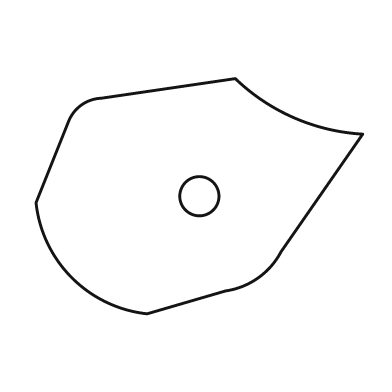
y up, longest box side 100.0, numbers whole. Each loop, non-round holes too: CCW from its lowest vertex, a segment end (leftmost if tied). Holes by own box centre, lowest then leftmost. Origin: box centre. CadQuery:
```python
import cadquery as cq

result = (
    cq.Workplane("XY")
    .moveTo(-16.0, -36.0)
    .lineTo(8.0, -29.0)
    .threePointArc((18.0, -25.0), (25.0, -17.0))
    .lineTo(50.0, 19.0)
    .threePointArc((29.0, 24.0), (11.0, 36.0))
    .lineTo(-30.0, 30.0)
    .threePointArc((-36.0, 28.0), (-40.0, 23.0))
    .lineTo(-50.0, -2.0)
    .threePointArc((-39.0, -25.0), (-16.0, -36.0))
    .close()
    .moveTo(0.0, 0.0)
    .circle(6.0)
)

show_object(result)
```